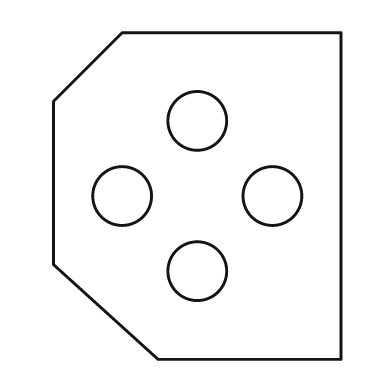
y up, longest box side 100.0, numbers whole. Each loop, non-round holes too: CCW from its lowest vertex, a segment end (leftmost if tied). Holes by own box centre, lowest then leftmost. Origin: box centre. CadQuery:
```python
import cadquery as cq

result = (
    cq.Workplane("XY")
    .moveTo(-12.0, -50.0)
    .lineTo(44.0, -50.0)
    .lineTo(44.0, 50.0)
    .lineTo(-23.0, 50.0)
    .lineTo(-44.0, 29.0)
    .lineTo(-44.0, -21.0)
    .close()
    .moveTo(0.0, -23.0)
    .circle(9.0)
    .moveTo(-23.0, 0.0)
    .circle(9.0)
    .moveTo(23.0, 0.0)
    .circle(9.0)
    .moveTo(0.0, 23.0)
    .circle(9.0)
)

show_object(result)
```